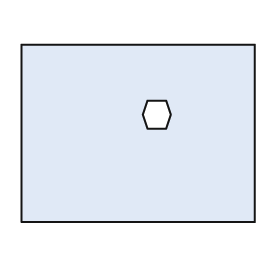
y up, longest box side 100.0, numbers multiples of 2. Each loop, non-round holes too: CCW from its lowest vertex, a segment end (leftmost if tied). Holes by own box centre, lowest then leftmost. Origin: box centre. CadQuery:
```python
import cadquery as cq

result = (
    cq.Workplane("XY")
    .moveTo(-50.0, -38.0)
    .lineTo(50.0, -38.0)
    .lineTo(50.0, 38.0)
    .lineTo(-50.0, 38.0)
    .close()
    .moveTo(4.0, 2.0)
    .lineTo(12.0, 2.0)
    .lineTo(14.0, 8.0)
    .lineTo(12.0, 14.0)
    .lineTo(4.0, 14.0)
    .lineTo(2.0, 8.0)
    .close()
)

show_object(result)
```